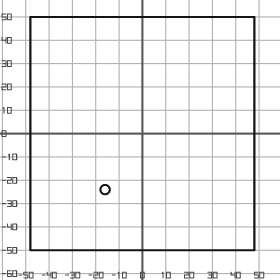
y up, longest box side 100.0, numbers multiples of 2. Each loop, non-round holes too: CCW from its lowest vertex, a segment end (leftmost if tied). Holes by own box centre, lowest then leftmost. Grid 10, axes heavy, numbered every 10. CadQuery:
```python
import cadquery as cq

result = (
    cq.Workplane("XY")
    .moveTo(-48.0, -50.0)
    .lineTo(48.0, -50.0)
    .lineTo(48.0, 50.0)
    .lineTo(-48.0, 50.0)
    .close()
    .moveTo(-16.0, -24.0)
    .circle(2.0)
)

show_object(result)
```